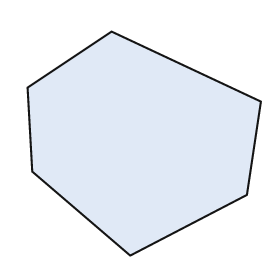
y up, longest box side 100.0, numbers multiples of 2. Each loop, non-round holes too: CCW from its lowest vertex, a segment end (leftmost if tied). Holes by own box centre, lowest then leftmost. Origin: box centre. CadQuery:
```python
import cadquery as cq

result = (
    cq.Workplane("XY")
    .moveTo(-6.0, -48.0)
    .lineTo(44.0, -22.0)
    .lineTo(50.0, 18.0)
    .lineTo(-14.0, 48.0)
    .lineTo(-50.0, 24.0)
    .lineTo(-48.0, -12.0)
    .close()
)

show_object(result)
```